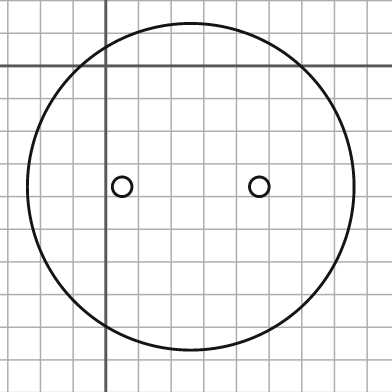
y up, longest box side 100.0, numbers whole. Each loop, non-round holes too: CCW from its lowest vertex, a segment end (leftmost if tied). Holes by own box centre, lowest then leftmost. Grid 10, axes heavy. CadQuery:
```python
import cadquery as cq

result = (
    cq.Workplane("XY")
    .moveTo(26.0, -37.0)
    .circle(50.0)
    .moveTo(5.0, -37.0)
    .circle(3.0)
    .moveTo(47.0, -37.0)
    .circle(3.0)
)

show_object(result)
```